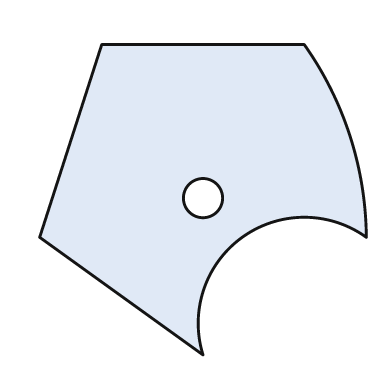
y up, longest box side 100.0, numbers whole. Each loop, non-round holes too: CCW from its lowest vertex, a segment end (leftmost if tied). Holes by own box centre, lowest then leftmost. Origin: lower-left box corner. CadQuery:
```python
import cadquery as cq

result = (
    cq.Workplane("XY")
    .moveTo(50.0, 0.0)
    .threePointArc((62.0, 36.0), (100.0, 36.0))
    .threePointArc((95.0, 67.0), (81.0, 95.0))
    .lineTo(19.0, 95.0)
    .lineTo(0.0, 36.0)
    .close()
    .moveTo(50.0, 48.0)
    .circle(6.0)
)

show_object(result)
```